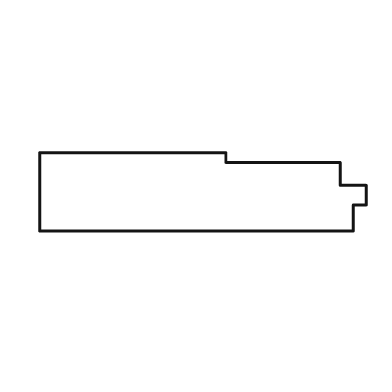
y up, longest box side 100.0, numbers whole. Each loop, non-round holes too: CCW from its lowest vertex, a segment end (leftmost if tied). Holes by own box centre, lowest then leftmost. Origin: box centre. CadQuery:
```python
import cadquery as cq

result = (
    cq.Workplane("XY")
    .moveTo(-50.0, -12.0)
    .lineTo(46.0, -12.0)
    .lineTo(46.0, -4.0)
    .lineTo(50.0, -4.0)
    .lineTo(50.0, 2.0)
    .lineTo(42.0, 2.0)
    .lineTo(42.0, 9.0)
    .lineTo(7.0, 9.0)
    .lineTo(7.0, 12.0)
    .lineTo(-50.0, 12.0)
    .close()
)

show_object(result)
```